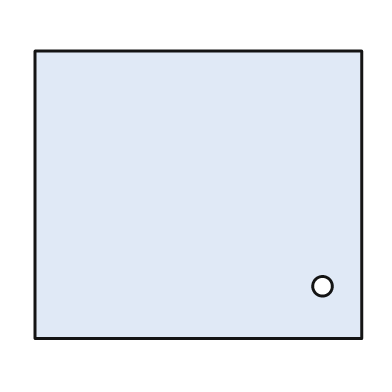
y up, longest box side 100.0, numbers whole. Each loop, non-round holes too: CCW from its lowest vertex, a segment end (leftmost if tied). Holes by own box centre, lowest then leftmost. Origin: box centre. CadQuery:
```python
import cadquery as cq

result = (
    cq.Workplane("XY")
    .moveTo(-50.0, -44.0)
    .lineTo(50.0, -44.0)
    .lineTo(50.0, 44.0)
    .lineTo(-50.0, 44.0)
    .close()
    .moveTo(38.0, -28.0)
    .circle(3.0)
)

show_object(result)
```